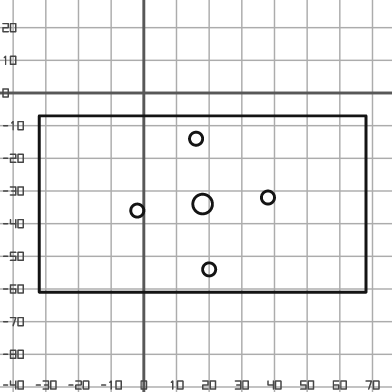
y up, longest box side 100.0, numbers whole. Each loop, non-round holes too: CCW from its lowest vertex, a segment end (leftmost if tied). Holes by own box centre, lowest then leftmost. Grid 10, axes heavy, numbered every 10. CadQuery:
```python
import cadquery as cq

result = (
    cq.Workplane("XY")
    .moveTo(-32.0, -61.0)
    .lineTo(68.0, -61.0)
    .lineTo(68.0, -7.0)
    .lineTo(-32.0, -7.0)
    .close()
    .moveTo(20.0, -54.0)
    .circle(2.0)
    .moveTo(-2.0, -36.0)
    .circle(2.0)
    .moveTo(18.0, -34.0)
    .circle(3.0)
    .moveTo(38.0, -32.0)
    .circle(2.0)
    .moveTo(16.0, -14.0)
    .circle(2.0)
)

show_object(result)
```